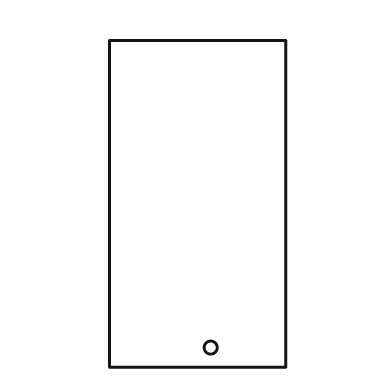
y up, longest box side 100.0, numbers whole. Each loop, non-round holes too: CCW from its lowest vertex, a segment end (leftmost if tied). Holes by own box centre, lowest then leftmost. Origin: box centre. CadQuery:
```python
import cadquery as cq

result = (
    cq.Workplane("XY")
    .moveTo(-27.0, -50.0)
    .lineTo(27.0, -50.0)
    .lineTo(27.0, 50.0)
    .lineTo(-27.0, 50.0)
    .close()
    .moveTo(4.0, -44.0)
    .circle(2.0)
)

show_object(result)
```